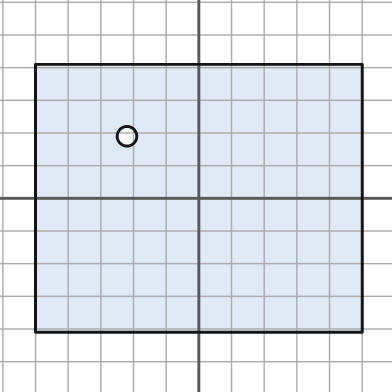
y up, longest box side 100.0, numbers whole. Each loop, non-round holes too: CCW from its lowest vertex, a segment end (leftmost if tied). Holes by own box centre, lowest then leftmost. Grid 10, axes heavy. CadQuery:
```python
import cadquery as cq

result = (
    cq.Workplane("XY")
    .moveTo(-50.0, -41.0)
    .lineTo(50.0, -41.0)
    .lineTo(50.0, 41.0)
    .lineTo(-50.0, 41.0)
    .close()
    .moveTo(-22.0, 19.0)
    .circle(3.0)
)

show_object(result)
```